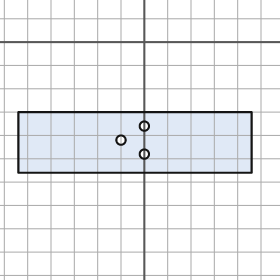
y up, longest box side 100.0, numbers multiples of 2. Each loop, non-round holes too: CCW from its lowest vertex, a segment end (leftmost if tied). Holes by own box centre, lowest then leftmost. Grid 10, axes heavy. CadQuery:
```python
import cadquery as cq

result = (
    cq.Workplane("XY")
    .moveTo(-54.0, -56.0)
    .lineTo(46.0, -56.0)
    .lineTo(46.0, -30.0)
    .lineTo(-54.0, -30.0)
    .close()
    .moveTo(0.0, -48.0)
    .circle(2.0)
    .moveTo(-10.0, -42.0)
    .circle(2.0)
    .moveTo(0.0, -36.0)
    .circle(2.0)
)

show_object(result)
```